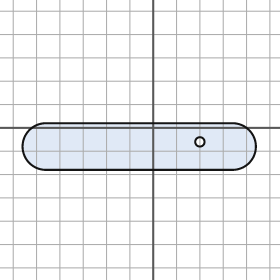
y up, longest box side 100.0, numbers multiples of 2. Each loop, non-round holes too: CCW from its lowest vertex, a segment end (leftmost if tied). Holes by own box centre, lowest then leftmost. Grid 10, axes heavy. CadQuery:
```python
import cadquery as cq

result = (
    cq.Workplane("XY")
    .moveTo(-46.0, -18.0)
    .lineTo(34.0, -18.0)
    .threePointArc((44.0, -8.0), (34.0, 2.0))
    .lineTo(-46.0, 2.0)
    .threePointArc((-56.0, -8.0), (-46.0, -18.0))
    .close()
    .moveTo(20.0, -6.0)
    .circle(2.0)
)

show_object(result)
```